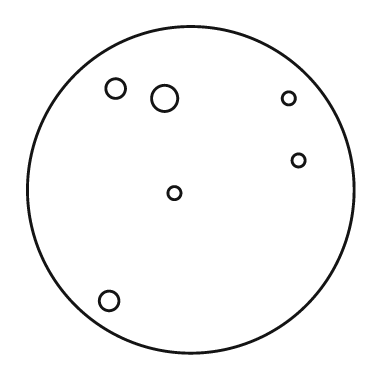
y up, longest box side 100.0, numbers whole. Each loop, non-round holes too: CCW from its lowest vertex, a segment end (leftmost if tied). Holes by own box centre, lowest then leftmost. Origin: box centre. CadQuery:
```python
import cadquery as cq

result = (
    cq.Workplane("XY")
    .moveTo(0.0, 0.0)
    .circle(50.0)
    .moveTo(-25.0, -34.0)
    .circle(3.0)
    .moveTo(-5.0, -1.0)
    .circle(2.0)
    .moveTo(33.0, 9.0)
    .circle(2.0)
    .moveTo(-8.0, 28.0)
    .circle(4.0)
    .moveTo(30.0, 28.0)
    .circle(2.0)
    .moveTo(-23.0, 31.0)
    .circle(3.0)
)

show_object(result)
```